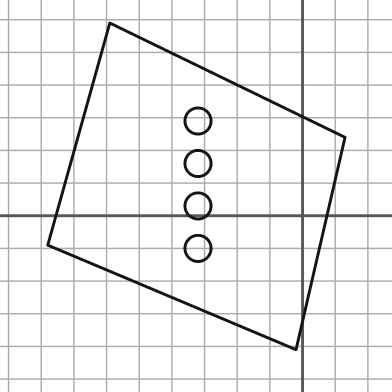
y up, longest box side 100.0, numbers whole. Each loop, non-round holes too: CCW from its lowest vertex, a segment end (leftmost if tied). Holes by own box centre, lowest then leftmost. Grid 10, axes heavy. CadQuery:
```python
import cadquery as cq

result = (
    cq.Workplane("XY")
    .moveTo(-2.0, -41.0)
    .lineTo(13.0, 24.0)
    .lineTo(-59.0, 59.0)
    .lineTo(-78.0, -9.0)
    .close()
    .moveTo(-32.0, -10.0)
    .circle(4.0)
    .moveTo(-32.0, 3.0)
    .circle(4.0)
    .moveTo(-32.0, 16.0)
    .circle(4.0)
    .moveTo(-32.0, 29.0)
    .circle(4.0)
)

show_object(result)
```